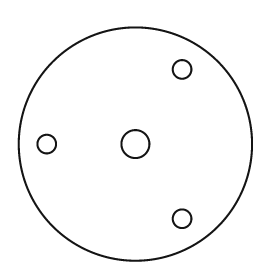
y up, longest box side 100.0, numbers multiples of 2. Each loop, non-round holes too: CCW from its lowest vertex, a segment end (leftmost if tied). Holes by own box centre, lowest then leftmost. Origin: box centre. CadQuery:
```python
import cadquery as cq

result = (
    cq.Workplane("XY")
    .moveTo(0.0, 0.0)
    .circle(50.0)
    .moveTo(20.0, -32.0)
    .circle(4.0)
    .moveTo(-38.0, 0.0)
    .circle(4.0)
    .moveTo(0.0, 0.0)
    .circle(6.0)
    .moveTo(20.0, 32.0)
    .circle(4.0)
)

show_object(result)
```